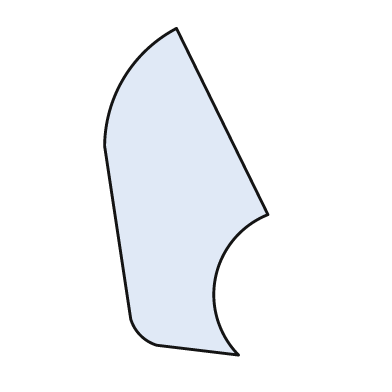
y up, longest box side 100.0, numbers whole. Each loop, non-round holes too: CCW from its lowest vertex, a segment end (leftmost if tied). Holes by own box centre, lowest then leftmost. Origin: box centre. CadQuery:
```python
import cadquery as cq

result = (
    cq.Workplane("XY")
    .moveTo(16.0, -50.0)
    .threePointArc((9.0, -26.0), (25.0, -7.0))
    .lineTo(-3.0, 50.0)
    .threePointArc((-19.0, 35.0), (-25.0, 14.0))
    .lineTo(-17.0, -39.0)
    .threePointArc((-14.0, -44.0), (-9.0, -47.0))
    .close()
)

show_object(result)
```